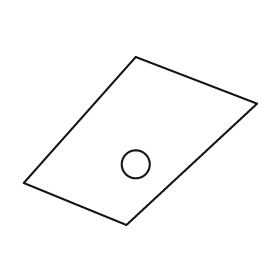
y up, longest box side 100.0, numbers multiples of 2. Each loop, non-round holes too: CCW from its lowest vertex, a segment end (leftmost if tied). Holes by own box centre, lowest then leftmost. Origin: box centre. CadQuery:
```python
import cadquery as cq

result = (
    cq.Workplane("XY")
    .moveTo(-6.0, -36.0)
    .lineTo(50.0, 16.0)
    .lineTo(-2.0, 36.0)
    .lineTo(-50.0, -18.0)
    .close()
    .moveTo(-2.0, -10.0)
    .circle(6.0)
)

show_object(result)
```